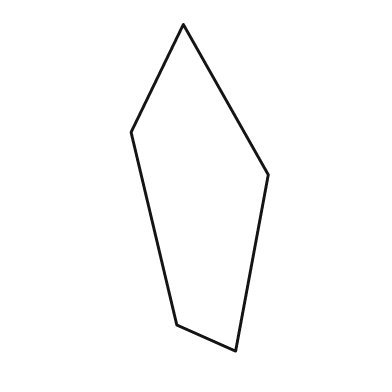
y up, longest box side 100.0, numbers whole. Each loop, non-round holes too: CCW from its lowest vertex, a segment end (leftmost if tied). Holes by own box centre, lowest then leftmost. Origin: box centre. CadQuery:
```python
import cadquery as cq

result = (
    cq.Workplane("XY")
    .moveTo(11.0, -50.0)
    .lineTo(21.0, 4.0)
    .lineTo(-5.0, 50.0)
    .lineTo(-21.0, 17.0)
    .lineTo(-7.0, -42.0)
    .close()
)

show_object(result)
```